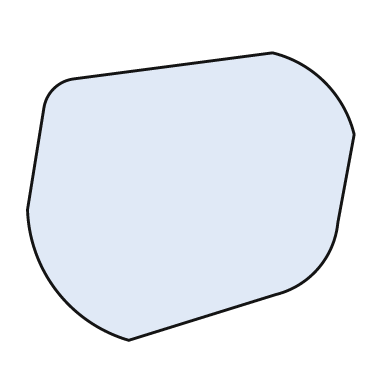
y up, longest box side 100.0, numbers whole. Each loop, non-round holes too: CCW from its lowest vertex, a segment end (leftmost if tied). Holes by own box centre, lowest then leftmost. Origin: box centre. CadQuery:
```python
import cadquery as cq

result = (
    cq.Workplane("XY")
    .moveTo(-19.0, -44.0)
    .lineTo(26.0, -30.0)
    .threePointArc((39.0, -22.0), (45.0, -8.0))
    .lineTo(50.0, 19.0)
    .threePointArc((41.0, 35.0), (25.0, 44.0))
    .lineTo(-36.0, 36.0)
    .threePointArc((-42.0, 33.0), (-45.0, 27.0))
    .lineTo(-50.0, -4.0)
    .threePointArc((-41.0, -29.0), (-19.0, -44.0))
    .close()
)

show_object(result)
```